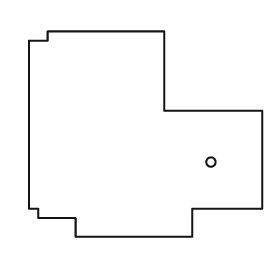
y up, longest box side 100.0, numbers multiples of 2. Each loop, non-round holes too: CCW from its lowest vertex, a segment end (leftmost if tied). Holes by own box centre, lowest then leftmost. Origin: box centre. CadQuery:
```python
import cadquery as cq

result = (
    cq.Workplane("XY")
    .moveTo(-30.0, -44.0)
    .lineTo(20.0, -44.0)
    .lineTo(20.0, -32.0)
    .lineTo(50.0, -32.0)
    .lineTo(50.0, 10.0)
    .lineTo(8.0, 10.0)
    .lineTo(8.0, 44.0)
    .lineTo(-42.0, 44.0)
    .lineTo(-42.0, 40.0)
    .lineTo(-50.0, 40.0)
    .lineTo(-50.0, -32.0)
    .lineTo(-46.0, -32.0)
    .lineTo(-46.0, -36.0)
    .lineTo(-30.0, -36.0)
    .close()
    .moveTo(28.0, -12.0)
    .circle(2.0)
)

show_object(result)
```